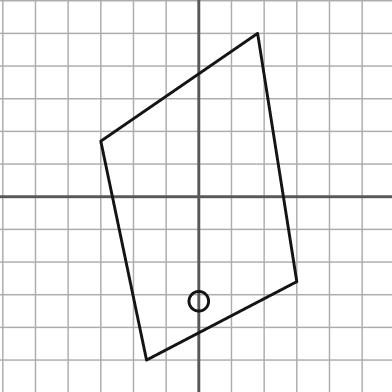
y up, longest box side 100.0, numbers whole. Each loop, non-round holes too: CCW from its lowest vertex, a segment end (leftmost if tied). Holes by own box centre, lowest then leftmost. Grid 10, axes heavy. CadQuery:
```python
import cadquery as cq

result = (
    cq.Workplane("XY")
    .moveTo(-16.0, -50.0)
    .lineTo(30.0, -26.0)
    .lineTo(18.0, 50.0)
    .lineTo(-30.0, 17.0)
    .close()
    .moveTo(0.0, -32.0)
    .circle(3.0)
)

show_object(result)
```